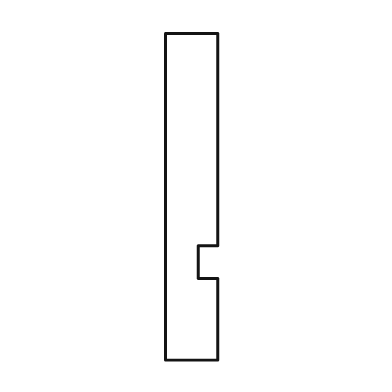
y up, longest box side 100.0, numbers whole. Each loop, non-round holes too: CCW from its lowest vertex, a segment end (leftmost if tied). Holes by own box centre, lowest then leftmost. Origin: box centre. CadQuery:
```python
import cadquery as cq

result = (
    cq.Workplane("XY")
    .moveTo(-8.0, -50.0)
    .lineTo(8.0, -50.0)
    .lineTo(8.0, -25.0)
    .lineTo(2.0, -25.0)
    .lineTo(2.0, -15.0)
    .lineTo(8.0, -15.0)
    .lineTo(8.0, 50.0)
    .lineTo(-8.0, 50.0)
    .close()
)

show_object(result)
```